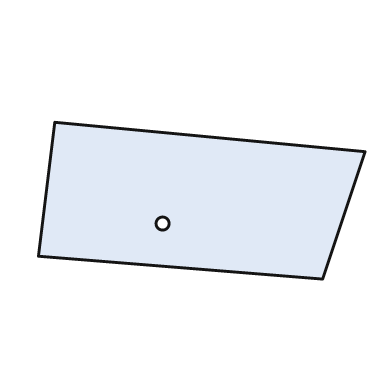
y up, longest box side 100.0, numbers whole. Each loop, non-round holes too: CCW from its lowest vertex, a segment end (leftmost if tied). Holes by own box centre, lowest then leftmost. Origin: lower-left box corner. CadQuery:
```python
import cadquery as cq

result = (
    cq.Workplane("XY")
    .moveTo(87.0, 0.0)
    .lineTo(100.0, 39.0)
    .lineTo(5.0, 48.0)
    .lineTo(0.0, 7.0)
    .close()
    .moveTo(38.0, 17.0)
    .circle(2.0)
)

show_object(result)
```